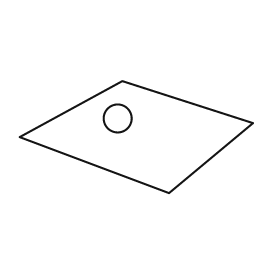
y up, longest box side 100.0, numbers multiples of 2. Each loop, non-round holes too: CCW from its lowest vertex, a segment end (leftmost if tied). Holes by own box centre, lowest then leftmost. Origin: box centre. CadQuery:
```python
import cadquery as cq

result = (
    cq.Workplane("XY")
    .moveTo(14.0, -24.0)
    .lineTo(50.0, 6.0)
    .lineTo(-6.0, 24.0)
    .lineTo(-50.0, 0.0)
    .close()
    .moveTo(-8.0, 8.0)
    .circle(6.0)
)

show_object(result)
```